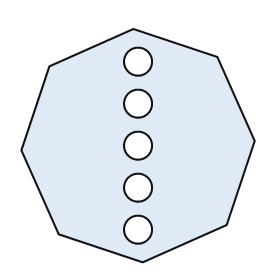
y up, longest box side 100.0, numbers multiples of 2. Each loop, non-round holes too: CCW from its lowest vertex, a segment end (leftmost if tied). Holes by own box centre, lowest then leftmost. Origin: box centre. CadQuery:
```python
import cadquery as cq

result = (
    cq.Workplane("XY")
    .moveTo(2.0, -50.0)
    .lineTo(38.0, -34.0)
    .lineTo(50.0, 2.0)
    .lineTo(34.0, 38.0)
    .lineTo(-2.0, 50.0)
    .lineTo(-38.0, 34.0)
    .lineTo(-50.0, -2.0)
    .lineTo(-34.0, -38.0)
    .close()
    .moveTo(0.0, -36.0)
    .circle(6.0)
    .moveTo(0.0, -18.0)
    .circle(6.0)
    .moveTo(0.0, 0.0)
    .circle(6.0)
    .moveTo(0.0, 18.0)
    .circle(6.0)
    .moveTo(0.0, 36.0)
    .circle(6.0)
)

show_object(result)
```